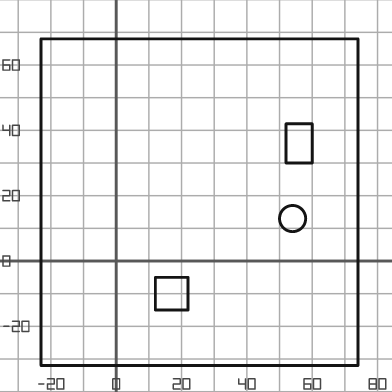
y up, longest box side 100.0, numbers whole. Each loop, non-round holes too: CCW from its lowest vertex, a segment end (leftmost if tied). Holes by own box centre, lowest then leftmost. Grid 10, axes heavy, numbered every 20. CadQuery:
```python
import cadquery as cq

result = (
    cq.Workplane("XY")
    .moveTo(-23.0, -32.0)
    .lineTo(74.0, -32.0)
    .lineTo(74.0, 68.0)
    .lineTo(-23.0, 68.0)
    .close()
    .moveTo(12.0, -15.0)
    .lineTo(22.0, -15.0)
    .lineTo(22.0, -5.0)
    .lineTo(12.0, -5.0)
    .close()
    .moveTo(54.0, 13.0)
    .circle(4.0)
    .moveTo(52.0, 30.0)
    .lineTo(60.0, 30.0)
    .lineTo(60.0, 42.0)
    .lineTo(52.0, 42.0)
    .close()
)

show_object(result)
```